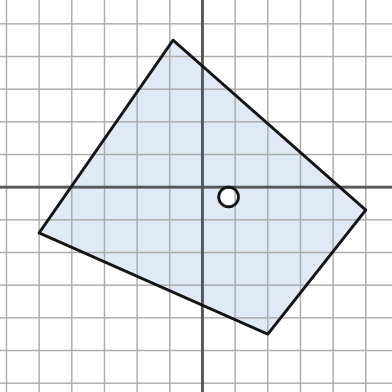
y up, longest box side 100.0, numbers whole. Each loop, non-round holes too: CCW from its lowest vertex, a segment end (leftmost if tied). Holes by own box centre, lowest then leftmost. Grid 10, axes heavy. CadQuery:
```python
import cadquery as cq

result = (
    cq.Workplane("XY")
    .moveTo(20.0, -45.0)
    .lineTo(50.0, -7.0)
    .lineTo(-9.0, 45.0)
    .lineTo(-50.0, -14.0)
    .close()
    .moveTo(8.0, -3.0)
    .circle(3.0)
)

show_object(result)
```